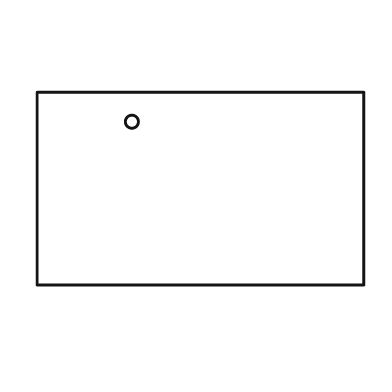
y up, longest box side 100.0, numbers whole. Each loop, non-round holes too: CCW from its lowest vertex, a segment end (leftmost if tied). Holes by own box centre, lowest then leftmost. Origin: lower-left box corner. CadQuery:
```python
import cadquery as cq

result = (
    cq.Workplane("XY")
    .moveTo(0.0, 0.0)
    .lineTo(100.0, 0.0)
    .lineTo(100.0, 59.0)
    .lineTo(0.0, 59.0)
    .close()
    .moveTo(29.0, 50.0)
    .circle(2.0)
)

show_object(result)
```